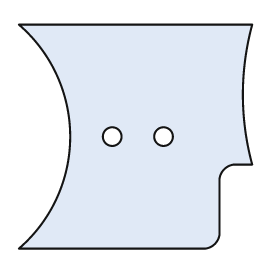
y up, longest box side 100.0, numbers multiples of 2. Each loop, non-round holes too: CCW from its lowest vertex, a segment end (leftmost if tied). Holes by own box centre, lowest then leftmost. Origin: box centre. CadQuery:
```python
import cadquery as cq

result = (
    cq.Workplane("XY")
    .moveTo(-50.0, -48.0)
    .lineTo(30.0, -48.0)
    .threePointArc((34.0, -46.0), (36.0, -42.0))
    .lineTo(36.0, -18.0)
    .threePointArc((38.0, -14.0), (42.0, -12.0))
    .lineTo(50.0, -12.0)
    .threePointArc((46.0, 18.0), (50.0, 48.0))
    .lineTo(-50.0, 48.0)
    .threePointArc((-28.0, 0.0), (-50.0, -48.0))
    .close()
    .moveTo(-10.0, 0.0)
    .circle(4.0)
    .moveTo(12.0, 0.0)
    .circle(4.0)
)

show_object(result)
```